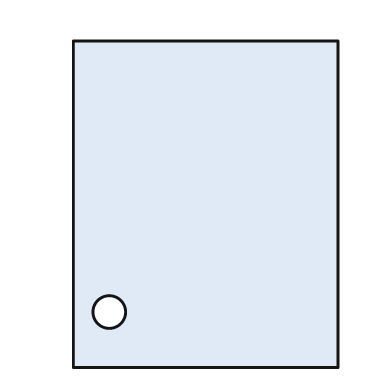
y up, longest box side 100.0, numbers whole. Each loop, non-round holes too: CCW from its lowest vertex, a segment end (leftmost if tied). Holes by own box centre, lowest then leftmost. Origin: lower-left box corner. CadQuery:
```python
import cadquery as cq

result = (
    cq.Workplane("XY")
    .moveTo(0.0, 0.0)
    .lineTo(81.0, 0.0)
    .lineTo(81.0, 100.0)
    .lineTo(0.0, 100.0)
    .close()
    .moveTo(11.0, 17.0)
    .circle(5.0)
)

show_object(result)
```